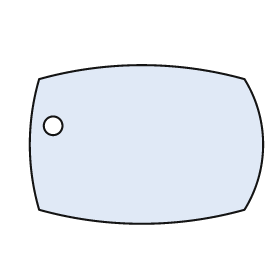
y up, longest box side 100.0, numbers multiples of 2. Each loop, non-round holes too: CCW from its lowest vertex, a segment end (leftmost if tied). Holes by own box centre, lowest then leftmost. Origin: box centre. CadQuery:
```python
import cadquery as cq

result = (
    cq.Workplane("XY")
    .moveTo(-46.0, -28.0)
    .threePointArc((-2.0, -34.0), (42.0, -28.0))
    .threePointArc((50.0, 0.0), (42.0, 28.0))
    .threePointArc((-2.0, 34.0), (-46.0, 28.0))
    .threePointArc((-50.0, 0.0), (-46.0, -28.0))
    .close()
    .moveTo(-40.0, 8.0)
    .circle(4.0)
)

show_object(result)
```